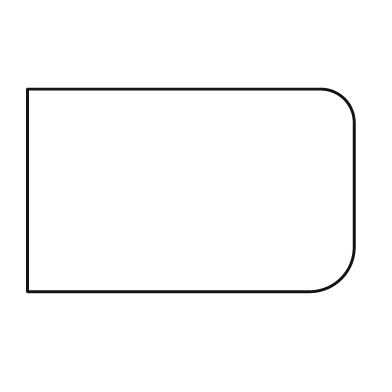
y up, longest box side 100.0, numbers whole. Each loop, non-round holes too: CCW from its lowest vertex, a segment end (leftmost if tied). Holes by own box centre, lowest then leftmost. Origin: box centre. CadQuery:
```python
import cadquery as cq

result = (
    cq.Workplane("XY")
    .moveTo(-50.0, -31.0)
    .lineTo(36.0, -31.0)
    .threePointArc((46.0, -27.0), (50.0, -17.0))
    .lineTo(50.0, 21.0)
    .threePointArc((47.0, 28.0), (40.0, 31.0))
    .lineTo(-50.0, 31.0)
    .close()
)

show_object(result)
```